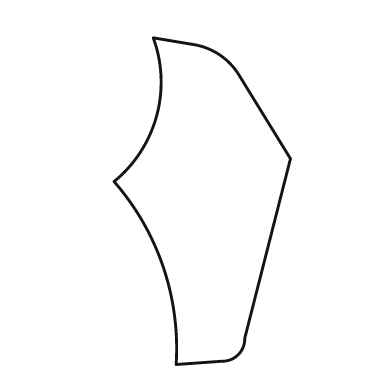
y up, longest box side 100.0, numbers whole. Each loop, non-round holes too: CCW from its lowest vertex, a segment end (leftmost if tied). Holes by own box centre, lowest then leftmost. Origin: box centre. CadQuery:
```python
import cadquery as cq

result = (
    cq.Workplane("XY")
    .moveTo(-8.0, -50.0)
    .lineTo(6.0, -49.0)
    .threePointArc((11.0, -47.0), (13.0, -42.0))
    .lineTo(27.0, 13.0)
    .lineTo(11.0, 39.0)
    .threePointArc((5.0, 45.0), (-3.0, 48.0))
    .lineTo(-15.0, 50.0)
    .threePointArc((-14.0, 26.0), (-27.0, 6.0))
    .threePointArc((-12.0, -20.0), (-8.0, -50.0))
    .close()
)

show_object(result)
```